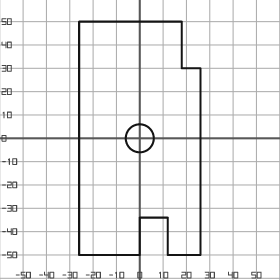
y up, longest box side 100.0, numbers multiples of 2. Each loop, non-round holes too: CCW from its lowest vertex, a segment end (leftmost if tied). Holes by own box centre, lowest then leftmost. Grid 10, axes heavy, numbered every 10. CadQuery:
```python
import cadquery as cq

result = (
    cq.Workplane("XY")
    .moveTo(-26.0, -50.0)
    .lineTo(0.0, -50.0)
    .lineTo(0.0, -34.0)
    .lineTo(12.0, -34.0)
    .lineTo(12.0, -50.0)
    .lineTo(26.0, -50.0)
    .lineTo(26.0, 30.0)
    .lineTo(18.0, 30.0)
    .lineTo(18.0, 50.0)
    .lineTo(-26.0, 50.0)
    .close()
    .moveTo(0.0, 0.0)
    .circle(6.0)
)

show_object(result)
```